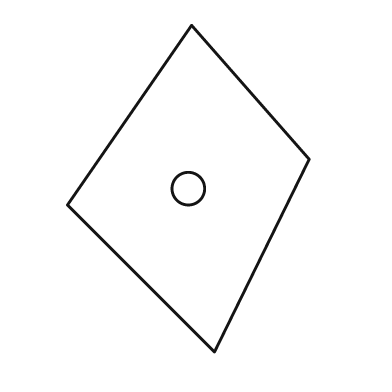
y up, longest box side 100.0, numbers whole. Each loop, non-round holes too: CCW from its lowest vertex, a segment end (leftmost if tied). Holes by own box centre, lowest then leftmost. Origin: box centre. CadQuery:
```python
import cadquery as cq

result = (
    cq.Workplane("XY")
    .moveTo(8.0, -50.0)
    .lineTo(37.0, 9.0)
    .lineTo(1.0, 50.0)
    .lineTo(-37.0, -5.0)
    .close()
    .moveTo(0.0, 0.0)
    .circle(5.0)
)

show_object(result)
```